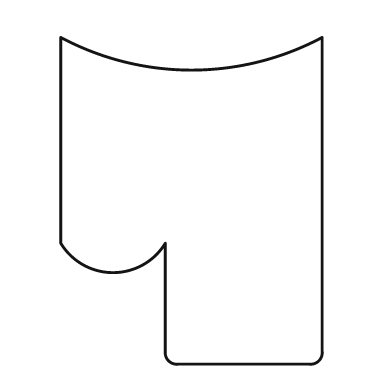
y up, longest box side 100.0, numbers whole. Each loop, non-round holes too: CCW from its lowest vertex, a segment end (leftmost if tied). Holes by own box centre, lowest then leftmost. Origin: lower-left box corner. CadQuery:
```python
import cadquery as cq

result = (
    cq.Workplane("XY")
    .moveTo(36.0, 0.0)
    .lineTo(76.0, 0.0)
    .threePointArc((79.0, 1.0), (80.0, 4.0))
    .lineTo(80.0, 100.0)
    .threePointArc((40.0, 90.0), (0.0, 100.0))
    .lineTo(0.0, 37.0)
    .threePointArc((16.0, 28.0), (32.0, 37.0))
    .lineTo(32.0, 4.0)
    .threePointArc((33.0, 1.0), (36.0, 0.0))
    .close()
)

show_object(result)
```